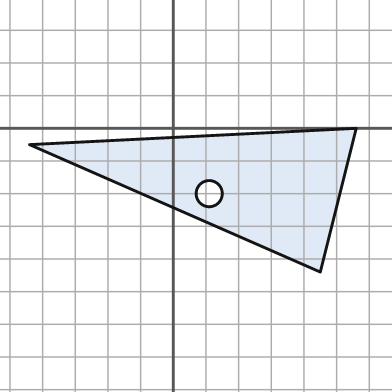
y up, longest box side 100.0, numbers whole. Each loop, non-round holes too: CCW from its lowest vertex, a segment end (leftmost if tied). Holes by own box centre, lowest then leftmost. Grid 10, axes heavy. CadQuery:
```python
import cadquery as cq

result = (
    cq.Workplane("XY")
    .moveTo(45.0, -44.0)
    .lineTo(56.0, 0.0)
    .lineTo(-44.0, -5.0)
    .close()
    .moveTo(11.0, -20.0)
    .circle(4.0)
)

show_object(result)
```